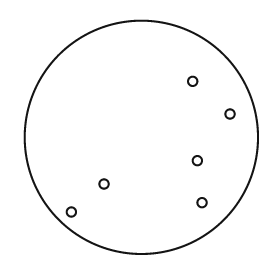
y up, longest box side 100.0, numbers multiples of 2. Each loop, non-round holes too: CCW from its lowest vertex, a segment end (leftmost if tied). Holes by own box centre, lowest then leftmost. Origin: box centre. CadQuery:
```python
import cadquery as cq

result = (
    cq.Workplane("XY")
    .moveTo(0.0, 0.0)
    .circle(50.0)
    .moveTo(-30.0, -32.0)
    .circle(2.0)
    .moveTo(26.0, -28.0)
    .circle(2.0)
    .moveTo(-16.0, -20.0)
    .circle(2.0)
    .moveTo(24.0, -10.0)
    .circle(2.0)
    .moveTo(38.0, 10.0)
    .circle(2.0)
    .moveTo(22.0, 24.0)
    .circle(2.0)
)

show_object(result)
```